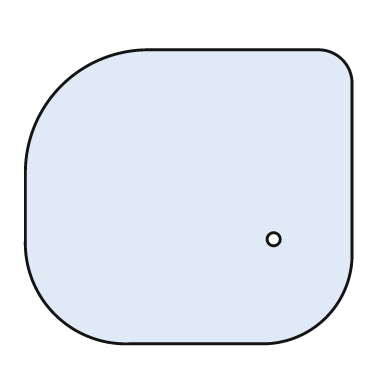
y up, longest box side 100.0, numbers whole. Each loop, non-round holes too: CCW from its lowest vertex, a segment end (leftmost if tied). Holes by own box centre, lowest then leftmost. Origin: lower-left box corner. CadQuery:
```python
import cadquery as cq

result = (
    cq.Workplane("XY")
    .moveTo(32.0, 0.0)
    .lineTo(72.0, 0.0)
    .threePointArc((92.0, 8.0), (100.0, 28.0))
    .lineTo(100.0, 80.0)
    .threePointArc((97.0, 87.0), (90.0, 90.0))
    .lineTo(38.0, 90.0)
    .threePointArc((11.0, 79.0), (0.0, 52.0))
    .lineTo(0.0, 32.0)
    .threePointArc((9.0, 9.0), (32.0, 0.0))
    .close()
    .moveTo(76.0, 32.0)
    .circle(2.0)
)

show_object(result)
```